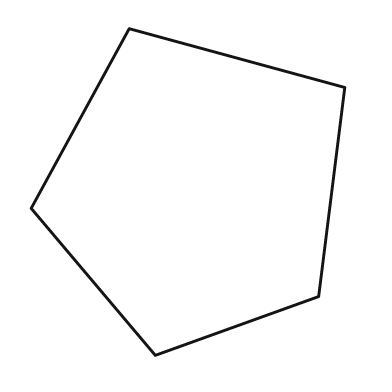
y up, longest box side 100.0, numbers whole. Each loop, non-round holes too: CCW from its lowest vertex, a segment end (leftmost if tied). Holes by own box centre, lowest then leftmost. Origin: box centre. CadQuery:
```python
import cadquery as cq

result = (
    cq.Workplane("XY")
    .moveTo(-10.0, -50.0)
    .lineTo(40.0, -32.0)
    .lineTo(48.0, 32.0)
    .lineTo(-18.0, 50.0)
    .lineTo(-48.0, -5.0)
    .close()
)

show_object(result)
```